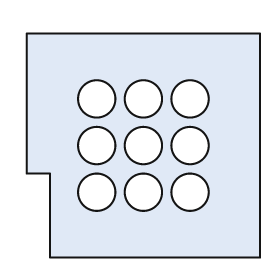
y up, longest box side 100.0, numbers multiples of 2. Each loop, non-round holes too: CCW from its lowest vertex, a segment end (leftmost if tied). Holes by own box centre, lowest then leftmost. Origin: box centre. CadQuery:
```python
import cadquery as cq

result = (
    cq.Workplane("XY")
    .moveTo(-40.0, -48.0)
    .lineTo(50.0, -48.0)
    .lineTo(50.0, 48.0)
    .lineTo(-50.0, 48.0)
    .lineTo(-50.0, -12.0)
    .lineTo(-40.0, -12.0)
    .close()
    .moveTo(-20.0, -20.0)
    .circle(8.0)
    .moveTo(0.0, -20.0)
    .circle(8.0)
    .moveTo(20.0, -20.0)
    .circle(8.0)
    .moveTo(-20.0, 0.0)
    .circle(8.0)
    .moveTo(0.0, 0.0)
    .circle(8.0)
    .moveTo(20.0, 0.0)
    .circle(8.0)
    .moveTo(-20.0, 20.0)
    .circle(8.0)
    .moveTo(0.0, 20.0)
    .circle(8.0)
    .moveTo(20.0, 20.0)
    .circle(8.0)
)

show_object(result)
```